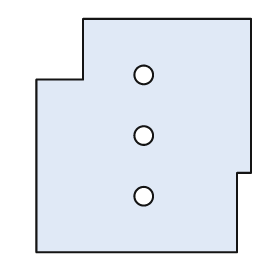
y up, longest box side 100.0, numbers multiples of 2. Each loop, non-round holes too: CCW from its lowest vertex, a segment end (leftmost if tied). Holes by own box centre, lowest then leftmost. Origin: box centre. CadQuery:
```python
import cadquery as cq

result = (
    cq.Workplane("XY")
    .moveTo(-46.0, -50.0)
    .lineTo(40.0, -50.0)
    .lineTo(40.0, -16.0)
    .lineTo(46.0, -16.0)
    .lineTo(46.0, 50.0)
    .lineTo(-26.0, 50.0)
    .lineTo(-26.0, 24.0)
    .lineTo(-46.0, 24.0)
    .close()
    .moveTo(0.0, -26.0)
    .circle(4.0)
    .moveTo(0.0, 0.0)
    .circle(4.0)
    .moveTo(0.0, 26.0)
    .circle(4.0)
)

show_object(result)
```